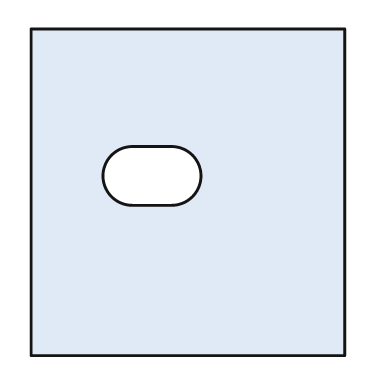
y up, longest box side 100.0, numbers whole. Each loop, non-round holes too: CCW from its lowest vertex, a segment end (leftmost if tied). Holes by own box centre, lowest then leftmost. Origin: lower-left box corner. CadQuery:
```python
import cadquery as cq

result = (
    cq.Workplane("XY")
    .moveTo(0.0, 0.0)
    .lineTo(96.0, 0.0)
    .lineTo(96.0, 100.0)
    .lineTo(0.0, 100.0)
    .close()
    .moveTo(31.0, 46.0)
    .lineTo(43.0, 46.0)
    .threePointArc((52.0, 55.0), (43.0, 64.0))
    .lineTo(31.0, 64.0)
    .threePointArc((22.0, 55.0), (31.0, 46.0))
    .close()
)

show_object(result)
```